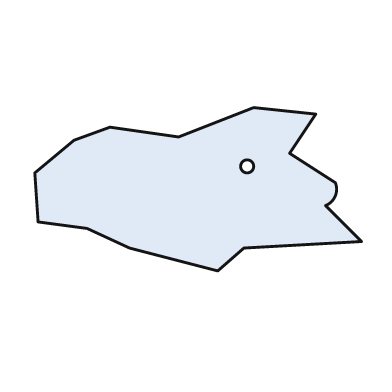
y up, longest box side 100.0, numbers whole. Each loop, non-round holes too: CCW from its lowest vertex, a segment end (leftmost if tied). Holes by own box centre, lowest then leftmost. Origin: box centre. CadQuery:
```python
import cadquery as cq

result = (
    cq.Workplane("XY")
    .moveTo(6.0, -25.0)
    .lineTo(14.0, -18.0)
    .lineTo(50.0, -16.0)
    .lineTo(39.0, -5.0)
    .threePointArc((42.0, -2.0), (42.0, 2.0))
    .lineTo(28.0, 11.0)
    .lineTo(36.0, 23.0)
    .lineTo(17.0, 25.0)
    .lineTo(-6.0, 16.0)
    .lineTo(-27.0, 19.0)
    .lineTo(-38.0, 15.0)
    .lineTo(-50.0, 5.0)
    .lineTo(-49.0, -10.0)
    .lineTo(-34.0, -12.0)
    .lineTo(-21.0, -18.0)
    .close()
    .moveTo(15.0, 7.0)
    .circle(2.0)
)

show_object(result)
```